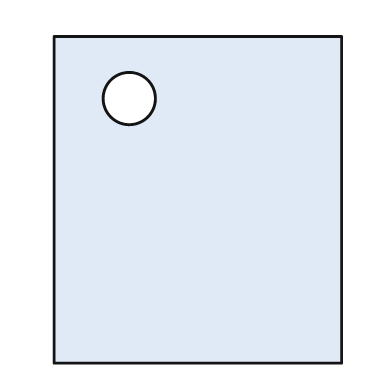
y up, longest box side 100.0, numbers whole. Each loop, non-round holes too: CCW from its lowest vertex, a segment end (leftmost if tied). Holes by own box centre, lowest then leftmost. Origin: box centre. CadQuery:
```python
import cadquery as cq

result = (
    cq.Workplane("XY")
    .moveTo(-44.0, -50.0)
    .lineTo(44.0, -50.0)
    .lineTo(44.0, 50.0)
    .lineTo(-44.0, 50.0)
    .close()
    .moveTo(-21.0, 31.0)
    .circle(8.0)
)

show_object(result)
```